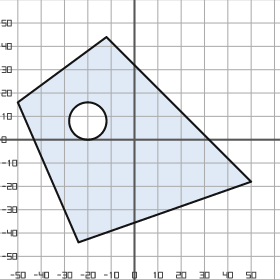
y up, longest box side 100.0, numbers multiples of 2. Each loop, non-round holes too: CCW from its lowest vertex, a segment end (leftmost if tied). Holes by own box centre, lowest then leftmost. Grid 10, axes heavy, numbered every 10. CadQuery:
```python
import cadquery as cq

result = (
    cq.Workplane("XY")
    .moveTo(-24.0, -44.0)
    .lineTo(50.0, -18.0)
    .lineTo(-12.0, 44.0)
    .lineTo(-50.0, 16.0)
    .close()
    .moveTo(-20.0, 8.0)
    .circle(8.0)
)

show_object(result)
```